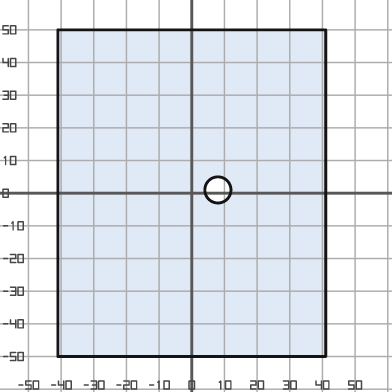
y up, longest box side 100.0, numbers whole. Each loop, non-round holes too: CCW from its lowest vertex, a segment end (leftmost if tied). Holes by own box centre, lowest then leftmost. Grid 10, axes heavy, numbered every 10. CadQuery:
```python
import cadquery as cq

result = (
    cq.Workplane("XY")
    .moveTo(-41.0, -50.0)
    .lineTo(41.0, -50.0)
    .lineTo(41.0, 50.0)
    .lineTo(-41.0, 50.0)
    .close()
    .moveTo(8.0, 1.0)
    .circle(4.0)
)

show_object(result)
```